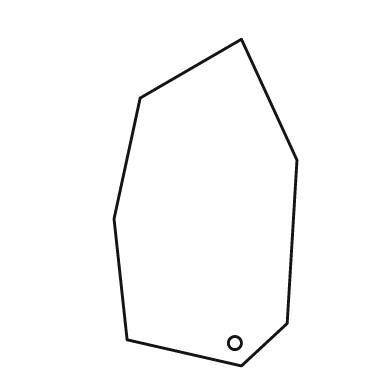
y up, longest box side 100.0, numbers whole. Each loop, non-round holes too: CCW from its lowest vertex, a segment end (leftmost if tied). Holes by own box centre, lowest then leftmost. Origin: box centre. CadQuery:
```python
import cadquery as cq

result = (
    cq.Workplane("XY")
    .moveTo(11.0, -50.0)
    .lineTo(25.0, -37.0)
    .lineTo(28.0, 13.0)
    .lineTo(11.0, 50.0)
    .lineTo(-20.0, 32.0)
    .lineTo(-28.0, -5.0)
    .lineTo(-24.0, -42.0)
    .close()
    .moveTo(9.0, -43.0)
    .circle(2.0)
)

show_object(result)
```